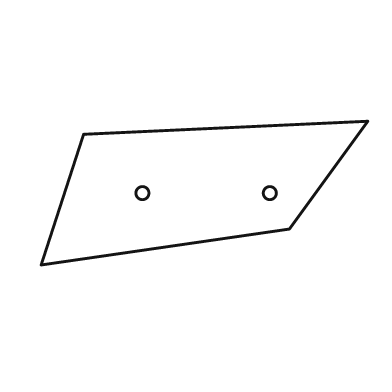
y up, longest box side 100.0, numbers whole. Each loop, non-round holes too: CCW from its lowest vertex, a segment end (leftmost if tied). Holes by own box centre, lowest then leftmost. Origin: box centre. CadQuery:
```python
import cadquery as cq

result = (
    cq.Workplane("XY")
    .moveTo(-50.0, -22.0)
    .lineTo(26.0, -11.0)
    .lineTo(50.0, 22.0)
    .lineTo(-37.0, 18.0)
    .close()
    .moveTo(-19.0, 0.0)
    .circle(2.0)
    .moveTo(20.0, 0.0)
    .circle(2.0)
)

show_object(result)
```